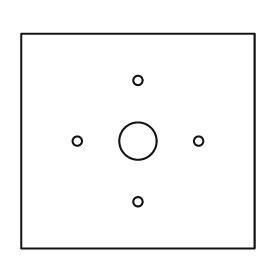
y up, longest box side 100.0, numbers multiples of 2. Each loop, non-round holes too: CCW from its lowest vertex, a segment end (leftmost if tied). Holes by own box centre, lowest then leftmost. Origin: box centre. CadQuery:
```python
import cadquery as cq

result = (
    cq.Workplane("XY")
    .moveTo(-50.0, -46.0)
    .lineTo(50.0, -46.0)
    .lineTo(50.0, 46.0)
    .lineTo(-50.0, 46.0)
    .close()
    .moveTo(0.0, -26.0)
    .circle(2.0)
    .moveTo(-26.0, 0.0)
    .circle(2.0)
    .moveTo(0.0, 0.0)
    .circle(8.0)
    .moveTo(26.0, 0.0)
    .circle(2.0)
    .moveTo(0.0, 26.0)
    .circle(2.0)
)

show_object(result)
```